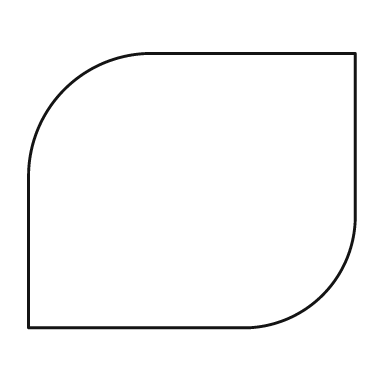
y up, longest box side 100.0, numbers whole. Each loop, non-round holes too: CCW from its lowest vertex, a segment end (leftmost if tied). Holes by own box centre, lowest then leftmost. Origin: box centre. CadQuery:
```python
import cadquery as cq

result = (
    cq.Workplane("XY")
    .moveTo(-50.0, -42.0)
    .lineTo(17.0, -42.0)
    .threePointArc((40.0, -32.0), (50.0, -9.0))
    .lineTo(50.0, 42.0)
    .lineTo(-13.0, 42.0)
    .threePointArc((-39.0, 31.0), (-50.0, 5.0))
    .close()
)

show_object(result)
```